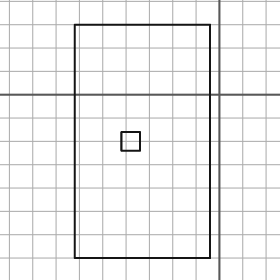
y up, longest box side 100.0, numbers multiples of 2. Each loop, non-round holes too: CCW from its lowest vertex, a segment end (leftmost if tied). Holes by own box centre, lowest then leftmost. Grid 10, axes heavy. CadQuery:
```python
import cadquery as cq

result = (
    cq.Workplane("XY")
    .moveTo(-62.0, -70.0)
    .lineTo(-4.0, -70.0)
    .lineTo(-4.0, 30.0)
    .lineTo(-62.0, 30.0)
    .close()
    .moveTo(-42.0, -24.0)
    .lineTo(-34.0, -24.0)
    .lineTo(-34.0, -16.0)
    .lineTo(-42.0, -16.0)
    .close()
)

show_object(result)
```